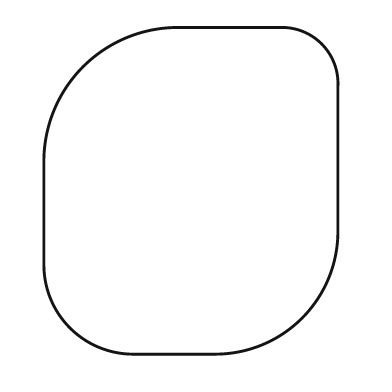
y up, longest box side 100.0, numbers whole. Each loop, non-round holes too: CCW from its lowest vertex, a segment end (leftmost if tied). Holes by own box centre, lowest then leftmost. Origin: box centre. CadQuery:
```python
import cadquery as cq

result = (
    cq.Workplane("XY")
    .moveTo(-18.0, -50.0)
    .lineTo(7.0, -50.0)
    .threePointArc((34.0, -39.0), (45.0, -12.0))
    .lineTo(45.0, 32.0)
    .threePointArc((40.0, 45.0), (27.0, 50.0))
    .lineTo(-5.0, 50.0)
    .threePointArc((-33.0, 38.0), (-45.0, 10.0))
    .lineTo(-45.0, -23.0)
    .threePointArc((-37.0, -42.0), (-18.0, -50.0))
    .close()
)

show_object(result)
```